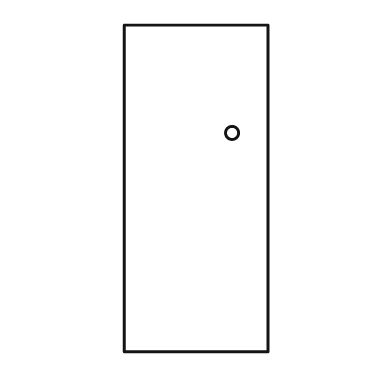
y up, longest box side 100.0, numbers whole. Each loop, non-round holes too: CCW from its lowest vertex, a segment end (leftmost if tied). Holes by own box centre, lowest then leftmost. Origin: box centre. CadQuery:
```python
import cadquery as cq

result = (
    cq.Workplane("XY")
    .moveTo(-22.0, -50.0)
    .lineTo(22.0, -50.0)
    .lineTo(22.0, 50.0)
    .lineTo(-22.0, 50.0)
    .close()
    .moveTo(11.0, 17.0)
    .circle(2.0)
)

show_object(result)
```